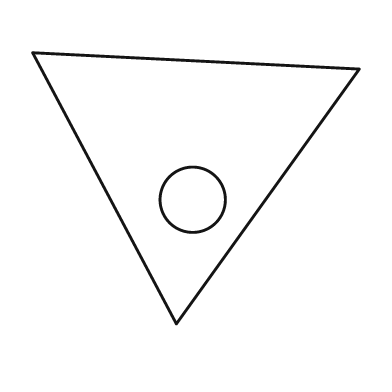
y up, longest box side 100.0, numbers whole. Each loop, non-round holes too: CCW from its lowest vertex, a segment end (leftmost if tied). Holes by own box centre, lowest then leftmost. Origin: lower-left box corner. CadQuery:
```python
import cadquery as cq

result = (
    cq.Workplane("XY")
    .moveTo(44.0, 0.0)
    .lineTo(100.0, 78.0)
    .lineTo(0.0, 83.0)
    .close()
    .moveTo(49.0, 38.0)
    .circle(10.0)
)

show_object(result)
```